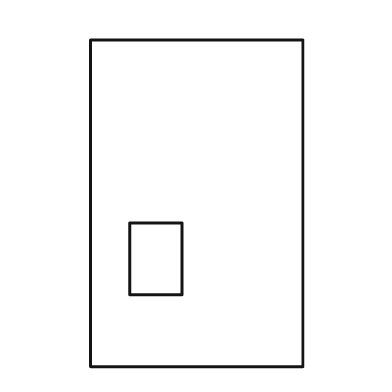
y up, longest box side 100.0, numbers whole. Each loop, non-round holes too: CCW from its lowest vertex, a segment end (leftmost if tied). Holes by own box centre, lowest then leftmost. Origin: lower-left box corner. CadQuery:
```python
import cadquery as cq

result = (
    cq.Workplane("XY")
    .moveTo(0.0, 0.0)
    .lineTo(65.0, 0.0)
    .lineTo(65.0, 100.0)
    .lineTo(0.0, 100.0)
    .close()
    .moveTo(12.0, 22.0)
    .lineTo(28.0, 22.0)
    .lineTo(28.0, 44.0)
    .lineTo(12.0, 44.0)
    .close()
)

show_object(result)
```